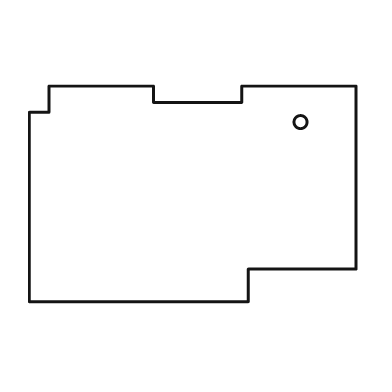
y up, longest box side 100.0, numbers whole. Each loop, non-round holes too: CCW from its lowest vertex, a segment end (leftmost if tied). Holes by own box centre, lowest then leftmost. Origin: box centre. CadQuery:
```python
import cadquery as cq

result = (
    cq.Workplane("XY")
    .moveTo(-50.0, -33.0)
    .lineTo(17.0, -33.0)
    .lineTo(17.0, -23.0)
    .lineTo(50.0, -23.0)
    .lineTo(50.0, 33.0)
    .lineTo(15.0, 33.0)
    .lineTo(15.0, 28.0)
    .lineTo(-12.0, 28.0)
    .lineTo(-12.0, 33.0)
    .lineTo(-44.0, 33.0)
    .lineTo(-44.0, 25.0)
    .lineTo(-50.0, 25.0)
    .close()
    .moveTo(33.0, 22.0)
    .circle(2.0)
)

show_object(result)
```